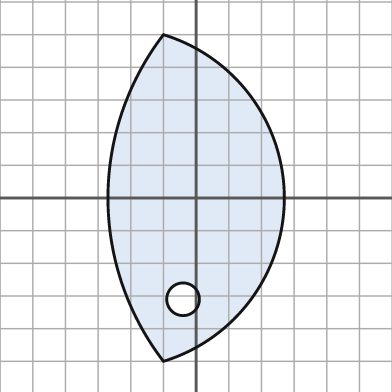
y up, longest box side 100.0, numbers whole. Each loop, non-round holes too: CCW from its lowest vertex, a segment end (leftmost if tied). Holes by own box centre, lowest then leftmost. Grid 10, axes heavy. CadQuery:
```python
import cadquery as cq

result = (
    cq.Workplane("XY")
    .moveTo(-10.0, -50.0)
    .threePointArc((27.0, 0.0), (-10.0, 50.0))
    .threePointArc((-27.0, 0.0), (-10.0, -50.0))
    .close()
    .moveTo(-4.0, -31.0)
    .circle(5.0)
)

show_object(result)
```